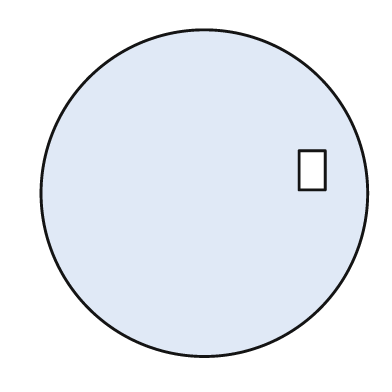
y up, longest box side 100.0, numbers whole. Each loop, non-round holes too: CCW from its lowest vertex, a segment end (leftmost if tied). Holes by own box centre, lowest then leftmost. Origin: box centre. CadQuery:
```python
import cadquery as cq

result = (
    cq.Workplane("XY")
    .moveTo(0.0, 0.0)
    .circle(50.0)
    .moveTo(29.0, 1.0)
    .lineTo(37.0, 1.0)
    .lineTo(37.0, 13.0)
    .lineTo(29.0, 13.0)
    .close()
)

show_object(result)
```